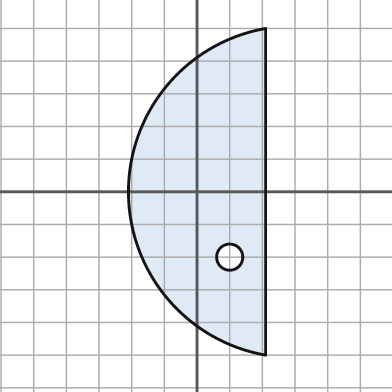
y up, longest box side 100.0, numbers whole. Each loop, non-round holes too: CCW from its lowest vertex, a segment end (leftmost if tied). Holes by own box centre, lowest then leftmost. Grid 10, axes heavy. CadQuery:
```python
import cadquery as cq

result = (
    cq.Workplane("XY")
    .moveTo(21.0, -50.0)
    .lineTo(21.0, 50.0)
    .threePointArc((-21.0, 0.0), (21.0, -50.0))
    .close()
    .moveTo(10.0, -20.0)
    .circle(4.0)
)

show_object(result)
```